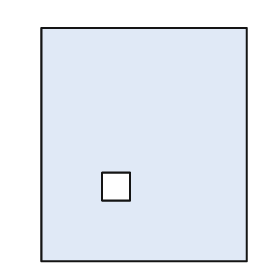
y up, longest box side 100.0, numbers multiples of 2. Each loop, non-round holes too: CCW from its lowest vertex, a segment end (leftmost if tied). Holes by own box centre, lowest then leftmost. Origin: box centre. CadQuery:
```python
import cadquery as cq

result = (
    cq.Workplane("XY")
    .moveTo(-44.0, -50.0)
    .lineTo(44.0, -50.0)
    .lineTo(44.0, 50.0)
    .lineTo(-44.0, 50.0)
    .close()
    .moveTo(-18.0, -24.0)
    .lineTo(-6.0, -24.0)
    .lineTo(-6.0, -12.0)
    .lineTo(-18.0, -12.0)
    .close()
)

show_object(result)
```